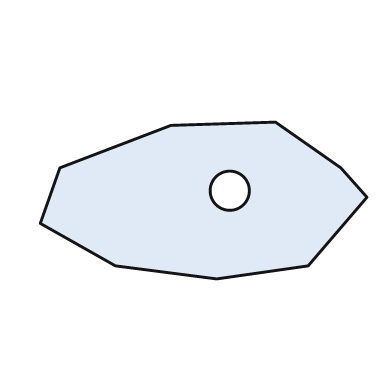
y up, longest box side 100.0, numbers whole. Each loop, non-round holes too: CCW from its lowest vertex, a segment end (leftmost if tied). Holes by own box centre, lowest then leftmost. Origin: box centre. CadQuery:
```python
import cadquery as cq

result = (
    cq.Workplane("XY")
    .moveTo(4.0, -24.0)
    .lineTo(32.0, -20.0)
    .lineTo(50.0, 1.0)
    .lineTo(42.0, 10.0)
    .lineTo(22.0, 24.0)
    .lineTo(-10.0, 23.0)
    .lineTo(-44.0, 10.0)
    .lineTo(-50.0, -7.0)
    .lineTo(-27.0, -20.0)
    .close()
    .moveTo(8.0, 3.0)
    .circle(6.0)
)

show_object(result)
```